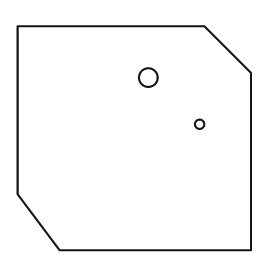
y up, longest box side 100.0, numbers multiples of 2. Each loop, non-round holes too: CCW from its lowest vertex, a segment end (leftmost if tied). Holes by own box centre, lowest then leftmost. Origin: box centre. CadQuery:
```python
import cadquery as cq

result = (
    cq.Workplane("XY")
    .moveTo(-32.0, -48.0)
    .lineTo(50.0, -48.0)
    .lineTo(50.0, 28.0)
    .lineTo(30.0, 48.0)
    .lineTo(-50.0, 48.0)
    .lineTo(-50.0, -24.0)
    .close()
    .moveTo(28.0, 6.0)
    .circle(2.0)
    .moveTo(6.0, 26.0)
    .circle(4.0)
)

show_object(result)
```